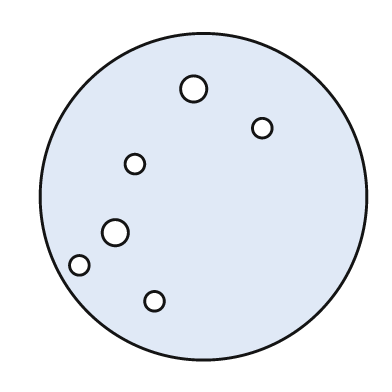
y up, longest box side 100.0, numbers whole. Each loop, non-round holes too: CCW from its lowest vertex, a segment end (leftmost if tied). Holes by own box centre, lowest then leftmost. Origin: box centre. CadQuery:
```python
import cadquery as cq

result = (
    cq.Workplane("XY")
    .moveTo(0.0, 0.0)
    .circle(50.0)
    .moveTo(-15.0, -32.0)
    .circle(3.0)
    .moveTo(-38.0, -21.0)
    .circle(3.0)
    .moveTo(-27.0, -11.0)
    .circle(4.0)
    .moveTo(-21.0, 10.0)
    .circle(3.0)
    .moveTo(18.0, 21.0)
    .circle(3.0)
    .moveTo(-3.0, 33.0)
    .circle(4.0)
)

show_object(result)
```